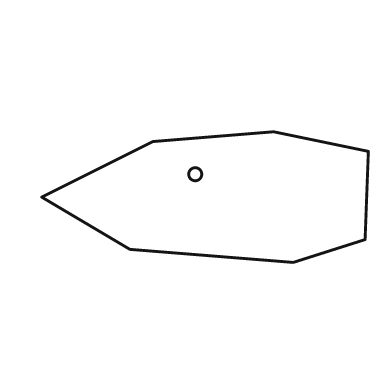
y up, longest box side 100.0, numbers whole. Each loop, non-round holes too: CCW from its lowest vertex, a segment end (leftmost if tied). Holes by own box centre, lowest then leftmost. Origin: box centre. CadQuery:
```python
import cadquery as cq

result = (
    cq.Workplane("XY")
    .moveTo(27.0, -20.0)
    .lineTo(49.0, -13.0)
    .lineTo(50.0, 14.0)
    .lineTo(21.0, 20.0)
    .lineTo(-16.0, 17.0)
    .lineTo(-50.0, 0.0)
    .lineTo(-23.0, -16.0)
    .close()
    .moveTo(-3.0, 7.0)
    .circle(2.0)
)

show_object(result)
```